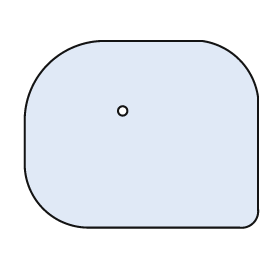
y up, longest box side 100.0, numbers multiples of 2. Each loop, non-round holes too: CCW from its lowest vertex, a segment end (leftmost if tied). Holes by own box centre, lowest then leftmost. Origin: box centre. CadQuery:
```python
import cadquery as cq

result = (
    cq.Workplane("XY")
    .moveTo(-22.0, -40.0)
    .lineTo(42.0, -40.0)
    .threePointArc((48.0, -38.0), (50.0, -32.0))
    .lineTo(50.0, 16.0)
    .threePointArc((42.0, 32.0), (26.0, 40.0))
    .lineTo(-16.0, 40.0)
    .threePointArc((-40.0, 30.0), (-50.0, 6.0))
    .lineTo(-50.0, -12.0)
    .threePointArc((-42.0, -32.0), (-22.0, -40.0))
    .close()
    .moveTo(-8.0, 10.0)
    .circle(2.0)
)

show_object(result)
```